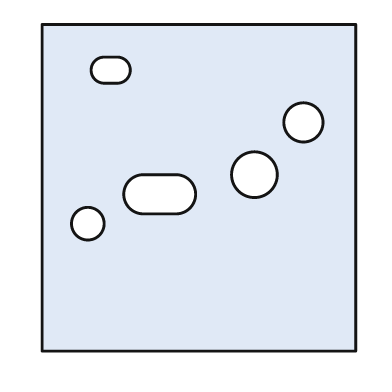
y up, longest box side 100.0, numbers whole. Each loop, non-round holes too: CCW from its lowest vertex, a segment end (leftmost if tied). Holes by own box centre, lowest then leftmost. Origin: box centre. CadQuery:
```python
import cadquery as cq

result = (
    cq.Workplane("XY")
    .moveTo(-48.0, -50.0)
    .lineTo(48.0, -50.0)
    .lineTo(48.0, 50.0)
    .lineTo(-48.0, 50.0)
    .close()
    .moveTo(-34.0, -11.0)
    .circle(5.0)
    .moveTo(-17.0, -8.0)
    .lineTo(-7.0, -8.0)
    .threePointArc((-1.0, -2.0), (-7.0, 4.0))
    .lineTo(-17.0, 4.0)
    .threePointArc((-23.0, -2.0), (-17.0, -8.0))
    .close()
    .moveTo(17.0, 4.0)
    .circle(7.0)
    .moveTo(32.0, 20.0)
    .circle(6.0)
    .moveTo(-29.0, 32.0)
    .lineTo(-25.0, 32.0)
    .threePointArc((-21.0, 36.0), (-25.0, 40.0))
    .lineTo(-29.0, 40.0)
    .threePointArc((-33.0, 36.0), (-29.0, 32.0))
    .close()
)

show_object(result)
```